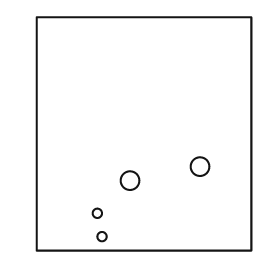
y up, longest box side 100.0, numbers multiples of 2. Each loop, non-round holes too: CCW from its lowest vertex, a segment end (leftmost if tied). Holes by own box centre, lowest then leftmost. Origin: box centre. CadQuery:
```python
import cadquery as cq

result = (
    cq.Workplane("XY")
    .moveTo(-46.0, -50.0)
    .lineTo(46.0, -50.0)
    .lineTo(46.0, 50.0)
    .lineTo(-46.0, 50.0)
    .close()
    .moveTo(-18.0, -44.0)
    .circle(2.0)
    .moveTo(-20.0, -34.0)
    .circle(2.0)
    .moveTo(-6.0, -20.0)
    .circle(4.0)
    .moveTo(24.0, -14.0)
    .circle(4.0)
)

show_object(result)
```